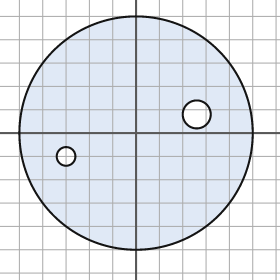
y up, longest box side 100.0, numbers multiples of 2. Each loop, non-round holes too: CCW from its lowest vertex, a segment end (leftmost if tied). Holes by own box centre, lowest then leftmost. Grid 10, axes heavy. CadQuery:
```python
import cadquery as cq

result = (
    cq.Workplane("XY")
    .moveTo(0.0, 0.0)
    .circle(50.0)
    .moveTo(-30.0, -10.0)
    .circle(4.0)
    .moveTo(26.0, 8.0)
    .circle(6.0)
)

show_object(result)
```